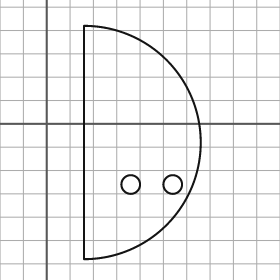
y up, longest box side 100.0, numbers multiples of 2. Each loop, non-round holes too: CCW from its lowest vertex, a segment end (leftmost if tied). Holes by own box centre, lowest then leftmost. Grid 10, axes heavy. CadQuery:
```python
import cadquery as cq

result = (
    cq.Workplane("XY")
    .moveTo(16.0, -58.0)
    .threePointArc((66.0, -8.0), (16.0, 42.0))
    .close()
    .moveTo(36.0, -26.0)
    .circle(4.0)
    .moveTo(54.0, -26.0)
    .circle(4.0)
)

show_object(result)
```